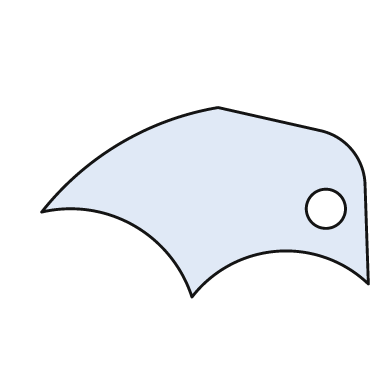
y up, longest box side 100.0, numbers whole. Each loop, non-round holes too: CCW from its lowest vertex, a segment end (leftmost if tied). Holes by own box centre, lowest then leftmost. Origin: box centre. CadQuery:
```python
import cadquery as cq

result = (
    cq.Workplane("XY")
    .moveTo(-4.0, -29.0)
    .threePointArc((22.0, -15.0), (50.0, -25.0))
    .lineTo(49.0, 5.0)
    .threePointArc((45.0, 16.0), (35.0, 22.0))
    .lineTo(4.0, 29.0)
    .threePointArc((-26.0, 18.0), (-50.0, -3.0))
    .threePointArc((-22.0, -7.0), (-4.0, -29.0))
    .close()
    .moveTo(37.0, -2.0)
    .circle(6.0)
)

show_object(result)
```